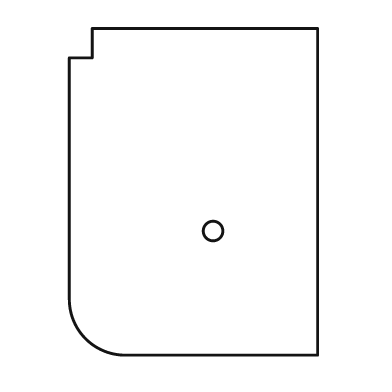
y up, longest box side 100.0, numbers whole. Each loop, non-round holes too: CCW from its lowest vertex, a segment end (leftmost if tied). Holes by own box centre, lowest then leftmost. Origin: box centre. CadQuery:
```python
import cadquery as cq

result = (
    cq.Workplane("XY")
    .moveTo(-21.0, -50.0)
    .lineTo(38.0, -50.0)
    .lineTo(38.0, 50.0)
    .lineTo(-31.0, 50.0)
    .lineTo(-31.0, 41.0)
    .lineTo(-38.0, 41.0)
    .lineTo(-38.0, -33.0)
    .threePointArc((-33.0, -45.0), (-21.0, -50.0))
    .close()
    .moveTo(6.0, -12.0)
    .circle(3.0)
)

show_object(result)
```